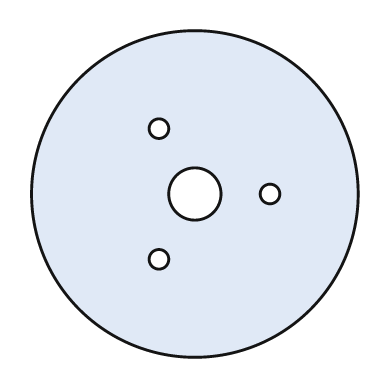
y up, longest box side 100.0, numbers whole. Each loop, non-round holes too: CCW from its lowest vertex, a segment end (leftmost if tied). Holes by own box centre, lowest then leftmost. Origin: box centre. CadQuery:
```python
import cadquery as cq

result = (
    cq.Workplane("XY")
    .moveTo(0.0, 0.0)
    .circle(50.0)
    .moveTo(-11.0, -20.0)
    .circle(3.0)
    .moveTo(0.0, 0.0)
    .circle(8.0)
    .moveTo(23.0, 0.0)
    .circle(3.0)
    .moveTo(-11.0, 20.0)
    .circle(3.0)
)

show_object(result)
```